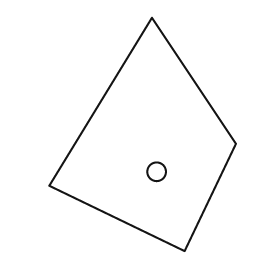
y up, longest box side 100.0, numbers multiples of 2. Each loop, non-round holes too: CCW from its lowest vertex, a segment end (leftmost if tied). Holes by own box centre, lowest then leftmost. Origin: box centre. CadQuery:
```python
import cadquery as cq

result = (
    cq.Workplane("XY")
    .moveTo(18.0, -50.0)
    .lineTo(40.0, -4.0)
    .lineTo(4.0, 50.0)
    .lineTo(-40.0, -22.0)
    .close()
    .moveTo(6.0, -16.0)
    .circle(4.0)
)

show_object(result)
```